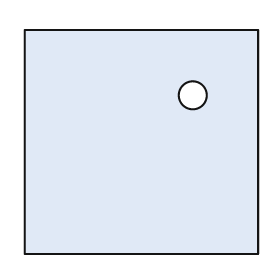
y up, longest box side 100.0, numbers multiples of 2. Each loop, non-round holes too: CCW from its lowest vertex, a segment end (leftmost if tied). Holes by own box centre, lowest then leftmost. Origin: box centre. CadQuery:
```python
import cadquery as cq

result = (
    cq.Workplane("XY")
    .moveTo(-50.0, -48.0)
    .lineTo(50.0, -48.0)
    .lineTo(50.0, 48.0)
    .lineTo(-50.0, 48.0)
    .close()
    .moveTo(22.0, 20.0)
    .circle(6.0)
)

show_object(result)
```